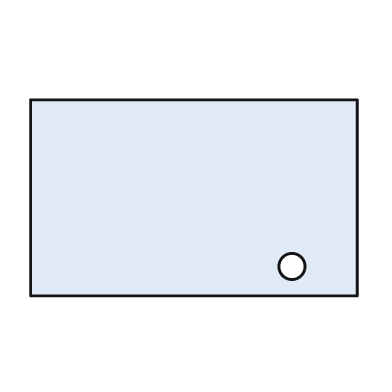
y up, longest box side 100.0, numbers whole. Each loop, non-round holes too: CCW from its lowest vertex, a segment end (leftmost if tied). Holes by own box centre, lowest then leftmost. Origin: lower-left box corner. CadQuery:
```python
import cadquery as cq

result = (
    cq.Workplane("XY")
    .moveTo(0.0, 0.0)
    .lineTo(100.0, 0.0)
    .lineTo(100.0, 60.0)
    .lineTo(0.0, 60.0)
    .close()
    .moveTo(80.0, 9.0)
    .circle(4.0)
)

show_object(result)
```